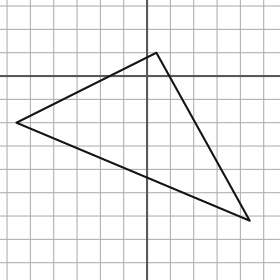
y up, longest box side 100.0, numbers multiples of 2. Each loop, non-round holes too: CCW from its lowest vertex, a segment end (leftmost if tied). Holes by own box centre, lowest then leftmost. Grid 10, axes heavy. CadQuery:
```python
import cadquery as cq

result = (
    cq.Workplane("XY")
    .moveTo(44.0, -62.0)
    .lineTo(4.0, 10.0)
    .lineTo(-56.0, -20.0)
    .close()
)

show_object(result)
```